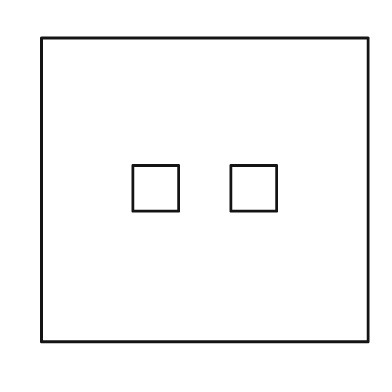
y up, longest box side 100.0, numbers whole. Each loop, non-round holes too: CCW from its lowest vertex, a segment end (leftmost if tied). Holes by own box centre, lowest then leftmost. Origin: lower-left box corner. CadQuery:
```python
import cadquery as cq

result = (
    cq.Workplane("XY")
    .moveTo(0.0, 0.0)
    .lineTo(100.0, 0.0)
    .lineTo(100.0, 93.0)
    .lineTo(0.0, 93.0)
    .close()
    .moveTo(28.0, 40.0)
    .lineTo(42.0, 40.0)
    .lineTo(42.0, 54.0)
    .lineTo(28.0, 54.0)
    .close()
    .moveTo(58.0, 40.0)
    .lineTo(72.0, 40.0)
    .lineTo(72.0, 54.0)
    .lineTo(58.0, 54.0)
    .close()
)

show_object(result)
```